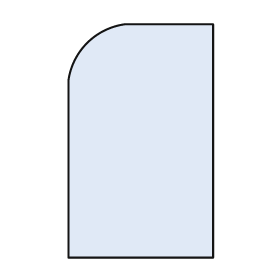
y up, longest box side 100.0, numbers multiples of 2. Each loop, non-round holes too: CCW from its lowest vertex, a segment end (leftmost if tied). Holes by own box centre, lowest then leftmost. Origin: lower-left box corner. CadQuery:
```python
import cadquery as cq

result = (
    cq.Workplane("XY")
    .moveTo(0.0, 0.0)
    .lineTo(62.0, 0.0)
    .lineTo(62.0, 100.0)
    .lineTo(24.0, 100.0)
    .threePointArc((8.0, 92.0), (0.0, 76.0))
    .close()
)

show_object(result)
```